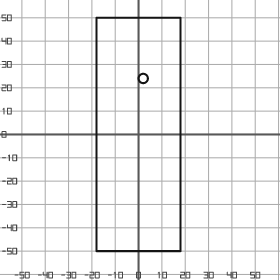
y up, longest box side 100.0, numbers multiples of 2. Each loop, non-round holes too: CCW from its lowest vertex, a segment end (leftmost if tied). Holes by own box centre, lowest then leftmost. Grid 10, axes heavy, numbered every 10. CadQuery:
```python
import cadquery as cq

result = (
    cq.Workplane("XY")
    .moveTo(-18.0, -50.0)
    .lineTo(18.0, -50.0)
    .lineTo(18.0, 50.0)
    .lineTo(-18.0, 50.0)
    .close()
    .moveTo(2.0, 24.0)
    .circle(2.0)
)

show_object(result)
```